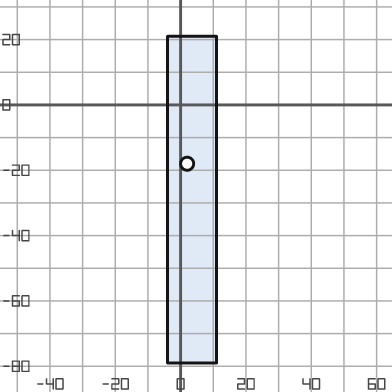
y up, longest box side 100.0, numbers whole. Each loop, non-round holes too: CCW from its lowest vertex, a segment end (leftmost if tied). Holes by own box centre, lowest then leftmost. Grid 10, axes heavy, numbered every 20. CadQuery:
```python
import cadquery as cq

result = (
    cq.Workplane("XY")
    .moveTo(-4.0, -79.0)
    .lineTo(11.0, -79.0)
    .lineTo(11.0, 21.0)
    .lineTo(-4.0, 21.0)
    .close()
    .moveTo(2.0, -18.0)
    .circle(2.0)
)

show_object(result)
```